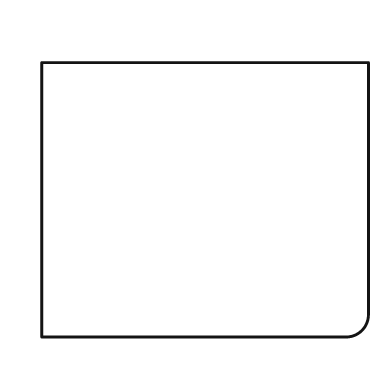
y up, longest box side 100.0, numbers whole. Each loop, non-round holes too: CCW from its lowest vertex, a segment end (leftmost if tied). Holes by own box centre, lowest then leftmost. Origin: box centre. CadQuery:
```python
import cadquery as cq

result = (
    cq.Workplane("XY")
    .moveTo(-50.0, -42.0)
    .lineTo(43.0, -42.0)
    .threePointArc((48.0, -40.0), (50.0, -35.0))
    .lineTo(50.0, 42.0)
    .lineTo(-50.0, 42.0)
    .close()
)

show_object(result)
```